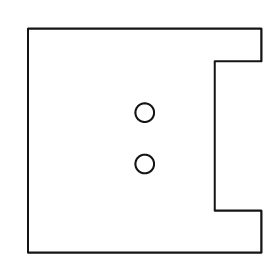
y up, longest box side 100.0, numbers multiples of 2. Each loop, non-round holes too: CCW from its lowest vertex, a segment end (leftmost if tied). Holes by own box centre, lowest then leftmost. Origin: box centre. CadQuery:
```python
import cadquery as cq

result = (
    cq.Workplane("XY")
    .moveTo(-50.0, -48.0)
    .lineTo(50.0, -48.0)
    .lineTo(50.0, -30.0)
    .lineTo(30.0, -30.0)
    .lineTo(30.0, 34.0)
    .lineTo(50.0, 34.0)
    .lineTo(50.0, 48.0)
    .lineTo(-50.0, 48.0)
    .close()
    .moveTo(0.0, -10.0)
    .circle(4.0)
    .moveTo(0.0, 12.0)
    .circle(4.0)
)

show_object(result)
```